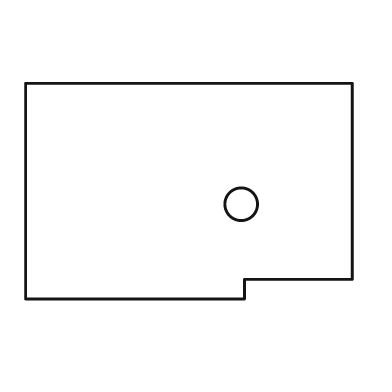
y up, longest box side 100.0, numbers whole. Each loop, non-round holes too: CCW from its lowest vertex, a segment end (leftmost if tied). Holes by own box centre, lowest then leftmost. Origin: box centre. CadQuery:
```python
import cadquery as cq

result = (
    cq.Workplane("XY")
    .moveTo(-50.0, -33.0)
    .lineTo(17.0, -33.0)
    .lineTo(17.0, -27.0)
    .lineTo(50.0, -27.0)
    .lineTo(50.0, 33.0)
    .lineTo(-50.0, 33.0)
    .close()
    .moveTo(16.0, -4.0)
    .circle(5.0)
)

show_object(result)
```